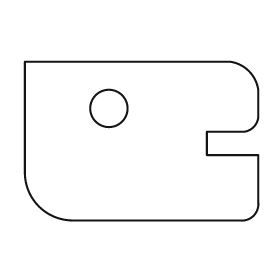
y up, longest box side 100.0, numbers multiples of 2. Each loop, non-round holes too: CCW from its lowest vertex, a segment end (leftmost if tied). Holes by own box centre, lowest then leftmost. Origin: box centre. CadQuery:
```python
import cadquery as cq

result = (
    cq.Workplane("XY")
    .moveTo(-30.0, -34.0)
    .lineTo(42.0, -34.0)
    .threePointArc((48.0, -32.0), (50.0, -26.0))
    .lineTo(50.0, -6.0)
    .lineTo(28.0, -6.0)
    .lineTo(28.0, 4.0)
    .lineTo(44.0, 4.0)
    .threePointArc((48.0, 6.0), (50.0, 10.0))
    .lineTo(50.0, 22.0)
    .threePointArc((46.0, 30.0), (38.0, 34.0))
    .lineTo(-50.0, 34.0)
    .lineTo(-50.0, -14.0)
    .threePointArc((-44.0, -28.0), (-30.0, -34.0))
    .close()
    .moveTo(-14.0, 14.0)
    .circle(8.0)
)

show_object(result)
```